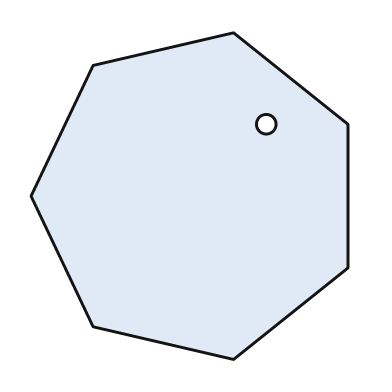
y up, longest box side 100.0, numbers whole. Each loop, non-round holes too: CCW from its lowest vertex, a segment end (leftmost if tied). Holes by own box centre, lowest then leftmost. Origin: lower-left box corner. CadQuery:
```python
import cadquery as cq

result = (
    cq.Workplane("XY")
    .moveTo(62.0, 0.0)
    .lineTo(97.0, 28.0)
    .lineTo(97.0, 72.0)
    .lineTo(62.0, 100.0)
    .lineTo(19.0, 90.0)
    .lineTo(0.0, 50.0)
    .lineTo(19.0, 10.0)
    .close()
    .moveTo(72.0, 72.0)
    .circle(3.0)
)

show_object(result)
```